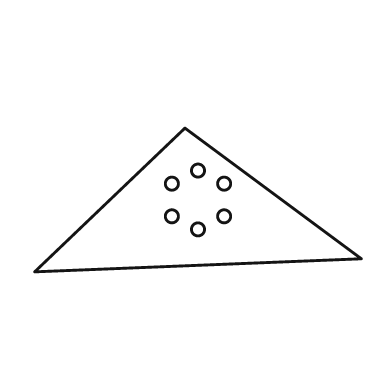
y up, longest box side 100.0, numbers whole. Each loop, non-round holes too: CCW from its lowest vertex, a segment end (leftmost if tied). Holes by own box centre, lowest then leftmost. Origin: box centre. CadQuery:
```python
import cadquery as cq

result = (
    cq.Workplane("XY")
    .moveTo(-50.0, -22.0)
    .lineTo(50.0, -18.0)
    .lineTo(-4.0, 22.0)
    .close()
    .moveTo(0.0, -9.0)
    .circle(2.0)
    .moveTo(-8.0, -5.0)
    .circle(2.0)
    .moveTo(8.0, -5.0)
    .circle(2.0)
    .moveTo(-8.0, 5.0)
    .circle(2.0)
    .moveTo(8.0, 5.0)
    .circle(2.0)
    .moveTo(0.0, 9.0)
    .circle(2.0)
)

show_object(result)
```